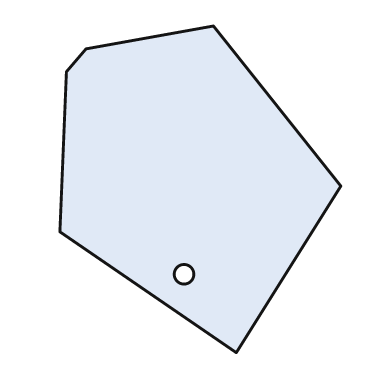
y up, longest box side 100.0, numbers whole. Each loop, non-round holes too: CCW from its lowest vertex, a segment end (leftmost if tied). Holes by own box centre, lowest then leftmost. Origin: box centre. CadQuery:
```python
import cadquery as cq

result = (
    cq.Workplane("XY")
    .moveTo(11.0, -50.0)
    .lineTo(43.0, 1.0)
    .lineTo(4.0, 50.0)
    .lineTo(-35.0, 43.0)
    .lineTo(-41.0, 36.0)
    .lineTo(-43.0, -13.0)
    .close()
    .moveTo(-5.0, -26.0)
    .circle(3.0)
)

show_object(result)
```